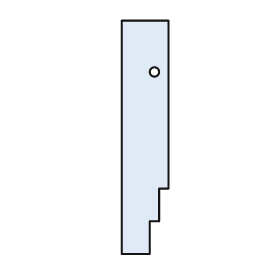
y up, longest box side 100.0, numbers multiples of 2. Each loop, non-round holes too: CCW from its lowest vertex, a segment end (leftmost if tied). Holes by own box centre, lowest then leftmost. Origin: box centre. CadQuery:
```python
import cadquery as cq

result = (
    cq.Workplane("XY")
    .moveTo(-10.0, -50.0)
    .lineTo(2.0, -50.0)
    .lineTo(2.0, -36.0)
    .lineTo(6.0, -36.0)
    .lineTo(6.0, -22.0)
    .lineTo(10.0, -22.0)
    .lineTo(10.0, 50.0)
    .lineTo(-10.0, 50.0)
    .close()
    .moveTo(4.0, 28.0)
    .circle(2.0)
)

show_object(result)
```